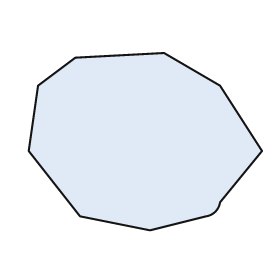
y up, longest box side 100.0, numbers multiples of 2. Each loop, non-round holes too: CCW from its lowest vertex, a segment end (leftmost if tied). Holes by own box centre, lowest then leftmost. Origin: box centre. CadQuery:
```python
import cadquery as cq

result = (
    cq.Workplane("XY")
    .moveTo(2.0, -38.0)
    .lineTo(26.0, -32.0)
    .threePointArc((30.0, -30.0), (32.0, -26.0))
    .lineTo(50.0, -4.0)
    .lineTo(32.0, 24.0)
    .lineTo(8.0, 38.0)
    .lineTo(-30.0, 36.0)
    .lineTo(-46.0, 24.0)
    .lineTo(-50.0, -4.0)
    .lineTo(-28.0, -32.0)
    .close()
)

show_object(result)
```